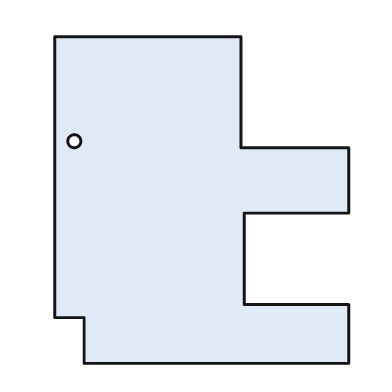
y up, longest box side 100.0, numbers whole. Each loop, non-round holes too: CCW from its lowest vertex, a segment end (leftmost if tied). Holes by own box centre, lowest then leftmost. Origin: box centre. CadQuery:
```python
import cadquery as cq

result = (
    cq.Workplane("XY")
    .moveTo(-36.0, -50.0)
    .lineTo(45.0, -50.0)
    .lineTo(45.0, -32.0)
    .lineTo(13.0, -32.0)
    .lineTo(13.0, -4.0)
    .lineTo(45.0, -4.0)
    .lineTo(45.0, 16.0)
    .lineTo(12.0, 16.0)
    .lineTo(12.0, 50.0)
    .lineTo(-45.0, 50.0)
    .lineTo(-45.0, -36.0)
    .lineTo(-36.0, -36.0)
    .close()
    .moveTo(-39.0, 18.0)
    .circle(2.0)
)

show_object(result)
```